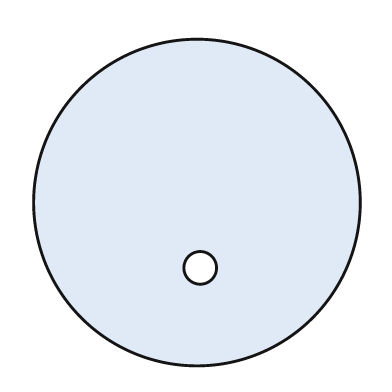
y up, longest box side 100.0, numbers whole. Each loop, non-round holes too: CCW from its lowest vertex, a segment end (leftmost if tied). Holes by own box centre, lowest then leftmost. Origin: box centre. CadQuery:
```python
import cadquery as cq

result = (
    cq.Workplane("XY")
    .moveTo(0.0, 0.0)
    .circle(50.0)
    .moveTo(1.0, -20.0)
    .circle(5.0)
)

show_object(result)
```